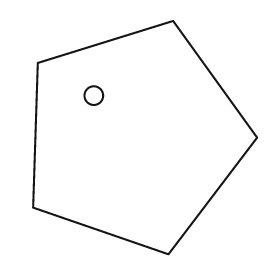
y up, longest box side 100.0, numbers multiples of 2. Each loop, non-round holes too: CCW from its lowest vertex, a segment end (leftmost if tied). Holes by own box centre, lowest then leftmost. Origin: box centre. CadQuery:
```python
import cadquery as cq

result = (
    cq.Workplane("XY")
    .moveTo(10.0, -50.0)
    .lineTo(48.0, 0.0)
    .lineTo(12.0, 50.0)
    .lineTo(-46.0, 32.0)
    .lineTo(-48.0, -30.0)
    .close()
    .moveTo(-22.0, 18.0)
    .circle(4.0)
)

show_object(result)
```